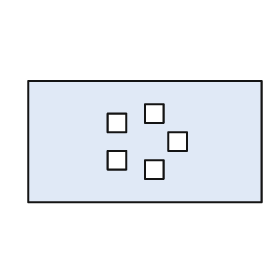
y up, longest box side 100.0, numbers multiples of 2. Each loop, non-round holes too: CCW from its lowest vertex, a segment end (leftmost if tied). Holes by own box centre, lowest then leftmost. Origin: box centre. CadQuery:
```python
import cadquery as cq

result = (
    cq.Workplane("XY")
    .moveTo(-50.0, -26.0)
    .lineTo(50.0, -26.0)
    .lineTo(50.0, 26.0)
    .lineTo(-50.0, 26.0)
    .close()
    .moveTo(0.0, -16.0)
    .lineTo(8.0, -16.0)
    .lineTo(8.0, -8.0)
    .lineTo(0.0, -8.0)
    .close()
    .moveTo(-16.0, -12.0)
    .lineTo(-8.0, -12.0)
    .lineTo(-8.0, -4.0)
    .lineTo(-16.0, -4.0)
    .close()
    .moveTo(10.0, -4.0)
    .lineTo(18.0, -4.0)
    .lineTo(18.0, 4.0)
    .lineTo(10.0, 4.0)
    .close()
    .moveTo(-16.0, 4.0)
    .lineTo(-8.0, 4.0)
    .lineTo(-8.0, 12.0)
    .lineTo(-16.0, 12.0)
    .close()
    .moveTo(0.0, 8.0)
    .lineTo(8.0, 8.0)
    .lineTo(8.0, 16.0)
    .lineTo(0.0, 16.0)
    .close()
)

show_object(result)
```